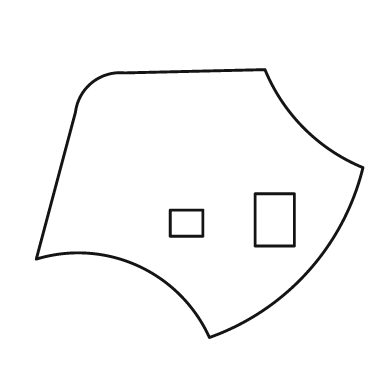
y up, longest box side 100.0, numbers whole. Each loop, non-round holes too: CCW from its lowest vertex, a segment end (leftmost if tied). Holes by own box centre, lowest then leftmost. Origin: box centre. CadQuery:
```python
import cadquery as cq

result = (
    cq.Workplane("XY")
    .moveTo(3.0, -41.0)
    .threePointArc((33.0, -21.0), (50.0, 11.0))
    .threePointArc((32.0, 23.0), (20.0, 41.0))
    .lineTo(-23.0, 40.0)
    .threePointArc((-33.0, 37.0), (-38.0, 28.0))
    .lineTo(-50.0, -17.0)
    .threePointArc((-19.0, -19.0), (3.0, -41.0))
    .close()
    .moveTo(-9.0, -10.0)
    .lineTo(1.0, -10.0)
    .lineTo(1.0, -2.0)
    .lineTo(-9.0, -2.0)
    .close()
    .moveTo(17.0, -13.0)
    .lineTo(29.0, -13.0)
    .lineTo(29.0, 3.0)
    .lineTo(17.0, 3.0)
    .close()
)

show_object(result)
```